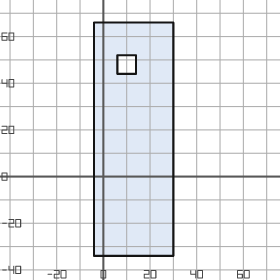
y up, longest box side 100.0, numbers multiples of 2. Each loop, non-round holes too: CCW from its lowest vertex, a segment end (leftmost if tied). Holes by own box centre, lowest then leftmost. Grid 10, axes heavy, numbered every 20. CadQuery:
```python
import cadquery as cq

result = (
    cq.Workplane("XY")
    .moveTo(-4.0, -34.0)
    .lineTo(30.0, -34.0)
    .lineTo(30.0, 66.0)
    .lineTo(-4.0, 66.0)
    .close()
    .moveTo(6.0, 44.0)
    .lineTo(14.0, 44.0)
    .lineTo(14.0, 52.0)
    .lineTo(6.0, 52.0)
    .close()
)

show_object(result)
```